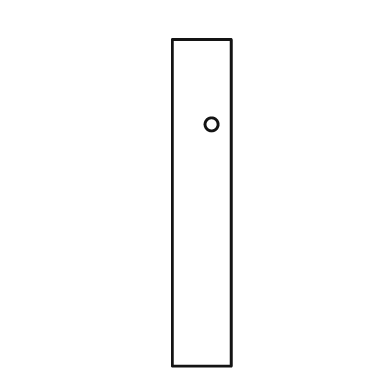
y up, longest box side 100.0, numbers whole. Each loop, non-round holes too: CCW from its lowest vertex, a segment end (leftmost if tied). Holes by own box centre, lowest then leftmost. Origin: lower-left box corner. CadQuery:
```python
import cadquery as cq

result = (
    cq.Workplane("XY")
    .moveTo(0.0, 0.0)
    .lineTo(18.0, 0.0)
    .lineTo(18.0, 100.0)
    .lineTo(0.0, 100.0)
    .close()
    .moveTo(12.0, 74.0)
    .circle(2.0)
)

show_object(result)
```